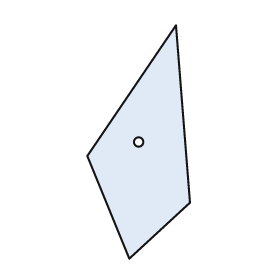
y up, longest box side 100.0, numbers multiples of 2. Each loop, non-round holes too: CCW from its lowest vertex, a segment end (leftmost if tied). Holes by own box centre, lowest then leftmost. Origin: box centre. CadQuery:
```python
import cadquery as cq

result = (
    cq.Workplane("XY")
    .moveTo(-4.0, -50.0)
    .lineTo(22.0, -26.0)
    .lineTo(16.0, 50.0)
    .lineTo(-22.0, -6.0)
    .close()
    .moveTo(0.0, 0.0)
    .circle(2.0)
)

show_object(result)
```